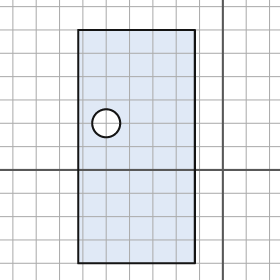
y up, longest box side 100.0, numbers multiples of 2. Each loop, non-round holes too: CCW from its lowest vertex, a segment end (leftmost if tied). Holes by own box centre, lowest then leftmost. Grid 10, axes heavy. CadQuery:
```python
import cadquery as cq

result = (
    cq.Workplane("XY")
    .moveTo(-62.0, -40.0)
    .lineTo(-12.0, -40.0)
    .lineTo(-12.0, 60.0)
    .lineTo(-62.0, 60.0)
    .close()
    .moveTo(-50.0, 20.0)
    .circle(6.0)
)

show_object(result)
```